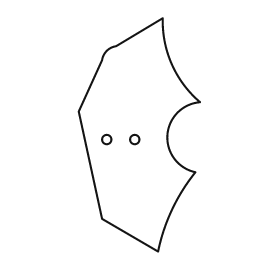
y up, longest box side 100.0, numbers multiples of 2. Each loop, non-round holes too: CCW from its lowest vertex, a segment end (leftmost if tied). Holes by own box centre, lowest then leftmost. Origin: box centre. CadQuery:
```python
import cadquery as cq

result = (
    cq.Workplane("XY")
    .moveTo(8.0, -50.0)
    .threePointArc((14.0, -32.0), (24.0, -16.0))
    .threePointArc((12.0, 0.0), (26.0, 14.0))
    .threePointArc((14.0, 30.0), (10.0, 50.0))
    .lineTo(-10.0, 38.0)
    .threePointArc((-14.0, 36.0), (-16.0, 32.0))
    .lineTo(-26.0, 10.0)
    .lineTo(-16.0, -36.0)
    .close()
    .moveTo(-14.0, -2.0)
    .circle(2.0)
    .moveTo(-2.0, -2.0)
    .circle(2.0)
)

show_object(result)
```